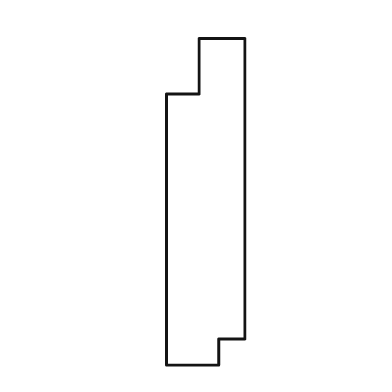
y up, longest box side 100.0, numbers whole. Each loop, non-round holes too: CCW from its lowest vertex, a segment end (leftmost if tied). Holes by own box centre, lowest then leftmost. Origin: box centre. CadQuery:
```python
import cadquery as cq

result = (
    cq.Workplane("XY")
    .moveTo(-12.0, -50.0)
    .lineTo(4.0, -50.0)
    .lineTo(4.0, -42.0)
    .lineTo(12.0, -42.0)
    .lineTo(12.0, 50.0)
    .lineTo(-2.0, 50.0)
    .lineTo(-2.0, 33.0)
    .lineTo(-12.0, 33.0)
    .close()
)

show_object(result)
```